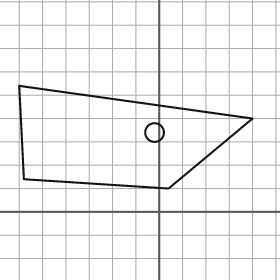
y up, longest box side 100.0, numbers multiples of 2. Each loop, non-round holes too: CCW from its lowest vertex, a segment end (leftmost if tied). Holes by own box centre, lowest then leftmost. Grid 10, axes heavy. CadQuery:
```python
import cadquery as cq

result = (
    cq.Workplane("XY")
    .moveTo(4.0, 10.0)
    .lineTo(40.0, 40.0)
    .lineTo(-60.0, 54.0)
    .lineTo(-58.0, 14.0)
    .close()
    .moveTo(-2.0, 34.0)
    .circle(4.0)
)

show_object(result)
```